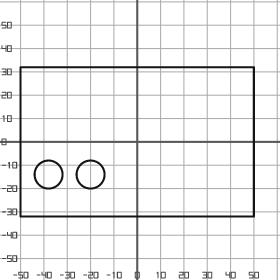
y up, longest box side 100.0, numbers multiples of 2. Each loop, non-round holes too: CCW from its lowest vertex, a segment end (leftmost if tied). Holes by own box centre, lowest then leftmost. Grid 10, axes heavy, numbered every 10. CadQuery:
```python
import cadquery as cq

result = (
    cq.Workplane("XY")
    .moveTo(-50.0, -32.0)
    .lineTo(50.0, -32.0)
    .lineTo(50.0, 32.0)
    .lineTo(-50.0, 32.0)
    .close()
    .moveTo(-38.0, -14.0)
    .circle(6.0)
    .moveTo(-20.0, -14.0)
    .circle(6.0)
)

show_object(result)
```